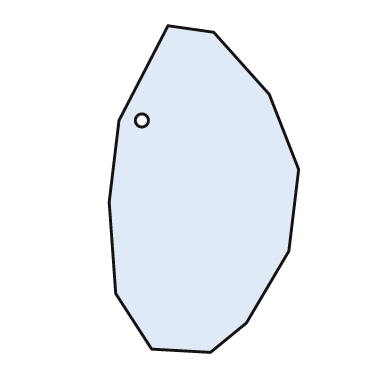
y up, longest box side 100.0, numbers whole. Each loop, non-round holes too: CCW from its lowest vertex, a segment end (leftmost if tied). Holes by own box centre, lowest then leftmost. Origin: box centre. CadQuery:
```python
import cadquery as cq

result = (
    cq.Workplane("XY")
    .moveTo(2.0, -50.0)
    .lineTo(13.0, -41.0)
    .lineTo(26.0, -19.0)
    .lineTo(29.0, 6.0)
    .lineTo(20.0, 29.0)
    .lineTo(3.0, 48.0)
    .lineTo(-11.0, 50.0)
    .lineTo(-26.0, 21.0)
    .lineTo(-29.0, -4.0)
    .lineTo(-27.0, -32.0)
    .lineTo(-16.0, -49.0)
    .close()
    .moveTo(-19.0, 21.0)
    .circle(2.0)
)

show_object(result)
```